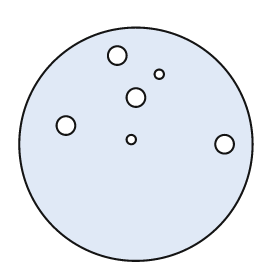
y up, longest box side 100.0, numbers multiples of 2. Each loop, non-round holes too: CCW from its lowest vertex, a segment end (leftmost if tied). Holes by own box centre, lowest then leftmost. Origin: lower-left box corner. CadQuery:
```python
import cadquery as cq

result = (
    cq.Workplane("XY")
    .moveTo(50.0, 50.0)
    .circle(50.0)
    .moveTo(88.0, 50.0)
    .circle(4.0)
    .moveTo(48.0, 52.0)
    .circle(2.0)
    .moveTo(20.0, 58.0)
    .circle(4.0)
    .moveTo(50.0, 70.0)
    .circle(4.0)
    .moveTo(60.0, 80.0)
    .circle(2.0)
    .moveTo(42.0, 88.0)
    .circle(4.0)
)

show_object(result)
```